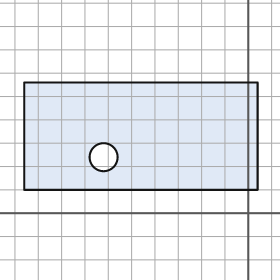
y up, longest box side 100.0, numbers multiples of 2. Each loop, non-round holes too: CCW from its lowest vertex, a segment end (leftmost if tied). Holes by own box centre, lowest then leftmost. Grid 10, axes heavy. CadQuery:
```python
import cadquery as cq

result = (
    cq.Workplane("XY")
    .moveTo(-96.0, 10.0)
    .lineTo(4.0, 10.0)
    .lineTo(4.0, 56.0)
    .lineTo(-96.0, 56.0)
    .close()
    .moveTo(-62.0, 24.0)
    .circle(6.0)
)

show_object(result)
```